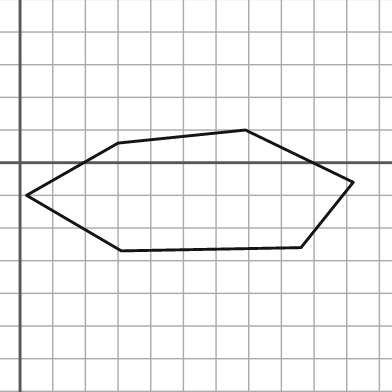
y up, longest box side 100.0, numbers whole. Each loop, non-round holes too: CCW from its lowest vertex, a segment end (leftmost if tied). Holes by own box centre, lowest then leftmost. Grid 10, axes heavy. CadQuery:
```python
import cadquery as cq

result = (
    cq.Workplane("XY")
    .moveTo(31.0, -27.0)
    .lineTo(86.0, -26.0)
    .lineTo(102.0, -6.0)
    .lineTo(69.0, 10.0)
    .lineTo(30.0, 6.0)
    .lineTo(2.0, -10.0)
    .close()
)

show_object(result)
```